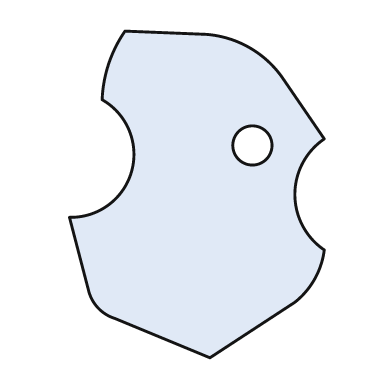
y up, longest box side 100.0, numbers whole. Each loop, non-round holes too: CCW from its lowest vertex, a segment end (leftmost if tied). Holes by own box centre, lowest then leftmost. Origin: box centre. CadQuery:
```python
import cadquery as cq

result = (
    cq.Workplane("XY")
    .moveTo(4.0, -50.0)
    .lineTo(30.0, -33.0)
    .threePointArc((36.0, -26.0), (39.0, -17.0))
    .threePointArc((30.0, 0.0), (39.0, 17.0))
    .lineTo(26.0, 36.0)
    .threePointArc((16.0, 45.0), (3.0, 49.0))
    .lineTo(-22.0, 50.0)
    .threePointArc((-27.0, 40.0), (-29.0, 29.0))
    .threePointArc((-20.0, 7.0), (-39.0, -7.0))
    .lineTo(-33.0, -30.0)
    .threePointArc((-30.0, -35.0), (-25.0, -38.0))
    .close()
    .moveTo(17.0, 15.0)
    .circle(6.0)
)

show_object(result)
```